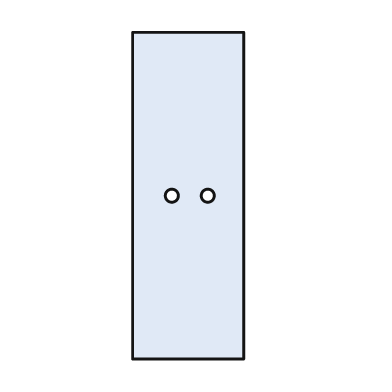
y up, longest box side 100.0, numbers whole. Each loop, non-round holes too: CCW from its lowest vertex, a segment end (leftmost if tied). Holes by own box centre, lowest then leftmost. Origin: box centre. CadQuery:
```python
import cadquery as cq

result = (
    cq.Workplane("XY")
    .moveTo(-17.0, -50.0)
    .lineTo(17.0, -50.0)
    .lineTo(17.0, 50.0)
    .lineTo(-17.0, 50.0)
    .close()
    .moveTo(-5.0, 0.0)
    .circle(2.0)
    .moveTo(6.0, 0.0)
    .circle(2.0)
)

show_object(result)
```